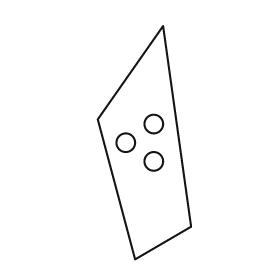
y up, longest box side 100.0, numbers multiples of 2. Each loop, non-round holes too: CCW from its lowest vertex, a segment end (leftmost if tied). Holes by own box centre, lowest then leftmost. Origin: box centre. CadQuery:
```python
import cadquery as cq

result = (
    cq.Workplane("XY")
    .moveTo(-4.0, -50.0)
    .lineTo(20.0, -36.0)
    .lineTo(8.0, 50.0)
    .lineTo(-20.0, 10.0)
    .close()
    .moveTo(4.0, -8.0)
    .circle(4.0)
    .moveTo(-8.0, 0.0)
    .circle(4.0)
    .moveTo(4.0, 8.0)
    .circle(4.0)
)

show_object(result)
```